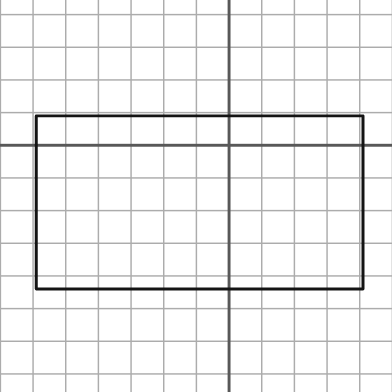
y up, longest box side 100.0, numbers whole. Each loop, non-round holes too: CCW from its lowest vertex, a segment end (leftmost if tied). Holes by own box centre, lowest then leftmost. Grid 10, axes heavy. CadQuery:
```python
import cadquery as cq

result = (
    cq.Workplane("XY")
    .moveTo(-59.0, -44.0)
    .lineTo(41.0, -44.0)
    .lineTo(41.0, 9.0)
    .lineTo(-59.0, 9.0)
    .close()
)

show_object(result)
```